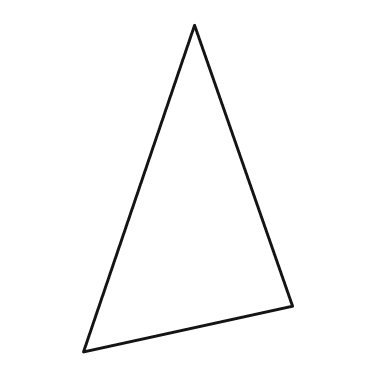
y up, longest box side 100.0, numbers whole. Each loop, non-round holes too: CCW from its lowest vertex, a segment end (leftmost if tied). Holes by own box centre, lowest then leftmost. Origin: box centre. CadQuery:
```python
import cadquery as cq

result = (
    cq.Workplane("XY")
    .moveTo(-32.0, -50.0)
    .lineTo(32.0, -36.0)
    .lineTo(2.0, 50.0)
    .close()
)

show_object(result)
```